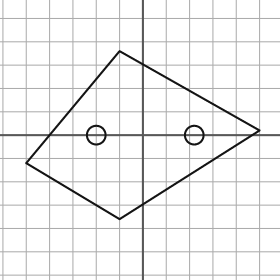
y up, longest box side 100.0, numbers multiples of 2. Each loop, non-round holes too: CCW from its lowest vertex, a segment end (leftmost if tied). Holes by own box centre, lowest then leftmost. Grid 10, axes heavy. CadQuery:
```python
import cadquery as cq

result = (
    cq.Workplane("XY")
    .moveTo(-10.0, -36.0)
    .lineTo(50.0, 2.0)
    .lineTo(-10.0, 36.0)
    .lineTo(-50.0, -12.0)
    .close()
    .moveTo(-20.0, 0.0)
    .circle(4.0)
    .moveTo(22.0, 0.0)
    .circle(4.0)
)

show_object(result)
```